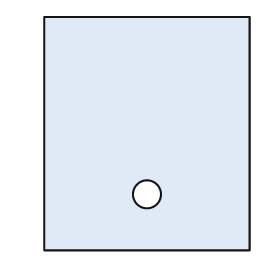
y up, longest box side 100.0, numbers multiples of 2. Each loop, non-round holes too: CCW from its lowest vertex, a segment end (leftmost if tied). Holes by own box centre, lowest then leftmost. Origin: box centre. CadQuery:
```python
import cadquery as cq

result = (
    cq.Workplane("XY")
    .moveTo(-44.0, -50.0)
    .lineTo(44.0, -50.0)
    .lineTo(44.0, 50.0)
    .lineTo(-44.0, 50.0)
    .close()
    .moveTo(0.0, -26.0)
    .circle(6.0)
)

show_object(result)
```